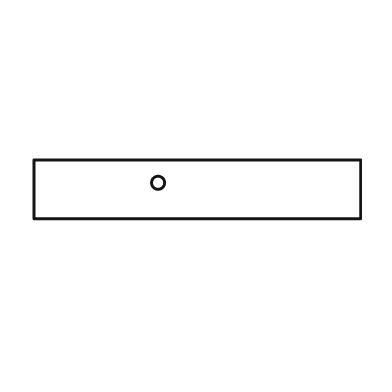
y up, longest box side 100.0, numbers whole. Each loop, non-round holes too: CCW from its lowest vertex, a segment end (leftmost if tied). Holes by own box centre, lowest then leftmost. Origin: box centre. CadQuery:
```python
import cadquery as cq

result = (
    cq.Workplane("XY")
    .moveTo(-50.0, -9.0)
    .lineTo(50.0, -9.0)
    .lineTo(50.0, 9.0)
    .lineTo(-50.0, 9.0)
    .close()
    .moveTo(-12.0, 2.0)
    .circle(2.0)
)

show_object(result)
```